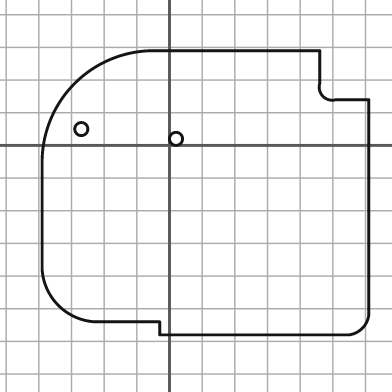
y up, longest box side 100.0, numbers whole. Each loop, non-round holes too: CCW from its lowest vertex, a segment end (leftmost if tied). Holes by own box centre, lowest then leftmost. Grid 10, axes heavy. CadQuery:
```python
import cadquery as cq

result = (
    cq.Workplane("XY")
    .moveTo(-3.0, -58.0)
    .lineTo(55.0, -58.0)
    .threePointArc((59.0, -56.0), (61.0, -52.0))
    .lineTo(61.0, 14.0)
    .lineTo(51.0, 14.0)
    .threePointArc((47.0, 15.0), (46.0, 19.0))
    .lineTo(46.0, 29.0)
    .lineTo(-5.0, 29.0)
    .threePointArc((-29.0, 19.0), (-39.0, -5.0))
    .lineTo(-39.0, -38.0)
    .threePointArc((-34.0, -49.0), (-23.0, -54.0))
    .lineTo(-3.0, -54.0)
    .close()
    .moveTo(2.0, 2.0)
    .circle(2.0)
    .moveTo(-27.0, 5.0)
    .circle(2.0)
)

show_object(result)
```